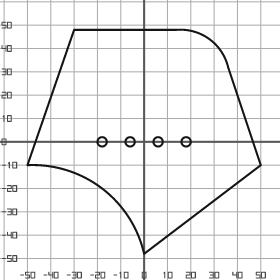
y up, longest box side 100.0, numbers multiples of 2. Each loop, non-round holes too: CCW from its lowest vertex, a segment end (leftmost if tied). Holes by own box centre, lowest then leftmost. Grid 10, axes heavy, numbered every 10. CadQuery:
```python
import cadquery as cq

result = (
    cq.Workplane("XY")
    .moveTo(0.0, -48.0)
    .lineTo(50.0, -10.0)
    .lineTo(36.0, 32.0)
    .threePointArc((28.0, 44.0), (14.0, 48.0))
    .lineTo(-30.0, 48.0)
    .lineTo(-50.0, -10.0)
    .threePointArc((-18.0, -20.0), (0.0, -48.0))
    .close()
    .moveTo(-18.0, 0.0)
    .circle(2.0)
    .moveTo(-6.0, 0.0)
    .circle(2.0)
    .moveTo(6.0, 0.0)
    .circle(2.0)
    .moveTo(18.0, 0.0)
    .circle(2.0)
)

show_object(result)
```